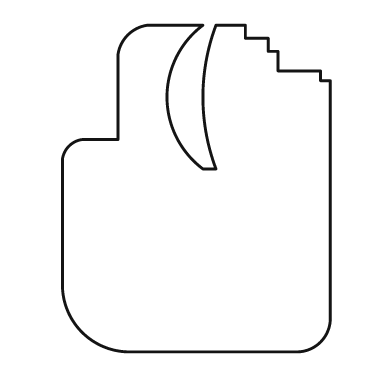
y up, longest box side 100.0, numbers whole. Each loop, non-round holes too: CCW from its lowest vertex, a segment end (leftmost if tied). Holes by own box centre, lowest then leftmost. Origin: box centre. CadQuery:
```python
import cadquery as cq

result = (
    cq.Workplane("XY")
    .moveTo(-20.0, -50.0)
    .lineTo(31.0, -50.0)
    .threePointArc((38.0, -47.0), (41.0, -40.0))
    .lineTo(41.0, 33.0)
    .lineTo(38.0, 33.0)
    .lineTo(38.0, 36.0)
    .lineTo(25.0, 36.0)
    .lineTo(25.0, 42.0)
    .lineTo(22.0, 42.0)
    .lineTo(22.0, 46.0)
    .lineTo(15.0, 46.0)
    .lineTo(15.0, 50.0)
    .lineTo(6.0, 50.0)
    .threePointArc((2.0, 28.0), (6.0, 6.0))
    .lineTo(2.0, 6.0)
    .threePointArc((-9.0, 28.0), (2.0, 50.0))
    .lineTo(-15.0, 50.0)
    .threePointArc((-21.0, 47.0), (-24.0, 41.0))
    .lineTo(-24.0, 15.0)
    .lineTo(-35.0, 15.0)
    .threePointArc((-39.0, 13.0), (-41.0, 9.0))
    .lineTo(-41.0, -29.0)
    .threePointArc((-35.0, -44.0), (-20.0, -50.0))
    .close()
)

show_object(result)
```